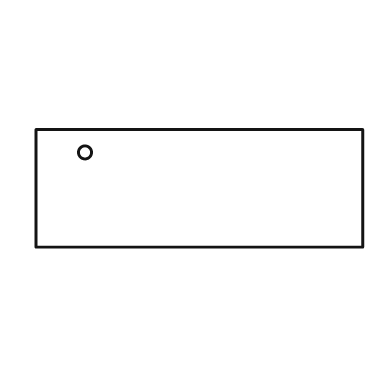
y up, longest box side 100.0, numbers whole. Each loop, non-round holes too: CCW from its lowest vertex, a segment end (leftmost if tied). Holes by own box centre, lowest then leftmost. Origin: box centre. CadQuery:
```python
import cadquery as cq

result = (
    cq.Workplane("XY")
    .moveTo(-50.0, -18.0)
    .lineTo(50.0, -18.0)
    .lineTo(50.0, 18.0)
    .lineTo(-50.0, 18.0)
    .close()
    .moveTo(-35.0, 11.0)
    .circle(2.0)
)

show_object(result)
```